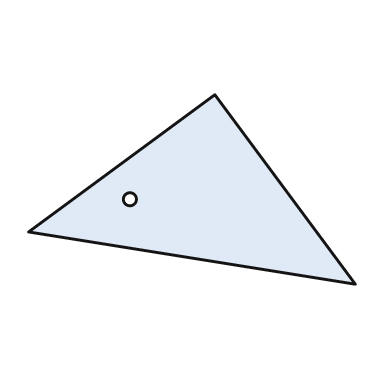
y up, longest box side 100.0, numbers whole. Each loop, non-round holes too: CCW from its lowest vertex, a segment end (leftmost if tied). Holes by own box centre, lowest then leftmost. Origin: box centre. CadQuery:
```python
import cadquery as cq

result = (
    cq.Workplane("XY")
    .moveTo(50.0, -29.0)
    .lineTo(7.0, 29.0)
    .lineTo(-50.0, -13.0)
    .close()
    .moveTo(-19.0, -3.0)
    .circle(2.0)
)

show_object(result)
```